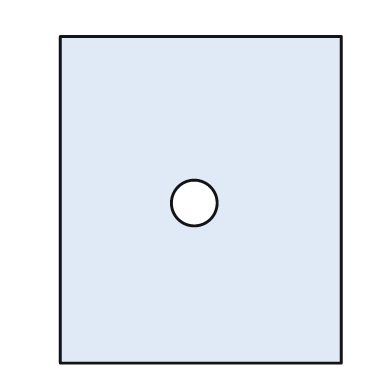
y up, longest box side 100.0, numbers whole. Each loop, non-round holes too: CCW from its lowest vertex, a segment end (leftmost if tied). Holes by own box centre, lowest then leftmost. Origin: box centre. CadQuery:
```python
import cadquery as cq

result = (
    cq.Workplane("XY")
    .moveTo(-43.0, -50.0)
    .lineTo(43.0, -50.0)
    .lineTo(43.0, 50.0)
    .lineTo(-43.0, 50.0)
    .close()
    .moveTo(-2.0, -1.0)
    .circle(7.0)
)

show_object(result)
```